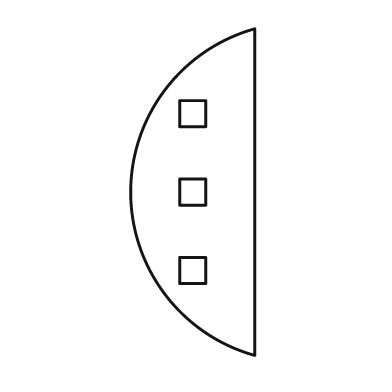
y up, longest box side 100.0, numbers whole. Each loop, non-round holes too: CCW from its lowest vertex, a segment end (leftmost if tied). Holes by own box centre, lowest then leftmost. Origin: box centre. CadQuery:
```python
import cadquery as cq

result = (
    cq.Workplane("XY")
    .moveTo(19.0, -50.0)
    .lineTo(19.0, 50.0)
    .threePointArc((-19.0, 0.0), (19.0, -50.0))
    .close()
    .moveTo(-4.0, -28.0)
    .lineTo(4.0, -28.0)
    .lineTo(4.0, -20.0)
    .lineTo(-4.0, -20.0)
    .close()
    .moveTo(-4.0, -4.0)
    .lineTo(4.0, -4.0)
    .lineTo(4.0, 4.0)
    .lineTo(-4.0, 4.0)
    .close()
    .moveTo(-4.0, 20.0)
    .lineTo(4.0, 20.0)
    .lineTo(4.0, 28.0)
    .lineTo(-4.0, 28.0)
    .close()
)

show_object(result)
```